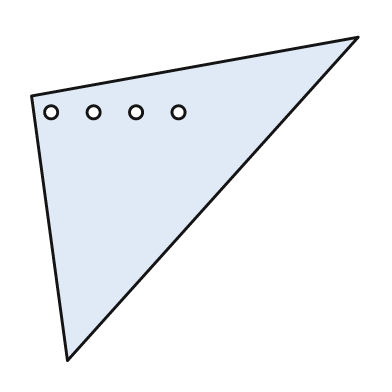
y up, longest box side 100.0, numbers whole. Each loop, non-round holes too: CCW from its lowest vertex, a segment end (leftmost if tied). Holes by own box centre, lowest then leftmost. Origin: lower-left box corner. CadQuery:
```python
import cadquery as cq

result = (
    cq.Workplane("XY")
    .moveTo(11.0, 0.0)
    .lineTo(100.0, 99.0)
    .lineTo(0.0, 81.0)
    .close()
    .moveTo(6.0, 76.0)
    .circle(2.0)
    .moveTo(19.0, 76.0)
    .circle(2.0)
    .moveTo(32.0, 76.0)
    .circle(2.0)
    .moveTo(45.0, 76.0)
    .circle(2.0)
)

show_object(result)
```